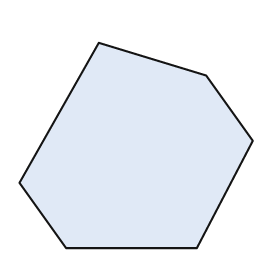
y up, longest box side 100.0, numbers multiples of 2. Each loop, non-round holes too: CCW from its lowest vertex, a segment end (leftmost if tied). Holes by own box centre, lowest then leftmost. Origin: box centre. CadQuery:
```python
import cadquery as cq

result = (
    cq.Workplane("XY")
    .moveTo(-30.0, -44.0)
    .lineTo(26.0, -44.0)
    .lineTo(50.0, 2.0)
    .lineTo(30.0, 30.0)
    .lineTo(-16.0, 44.0)
    .lineTo(-50.0, -16.0)
    .close()
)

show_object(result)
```